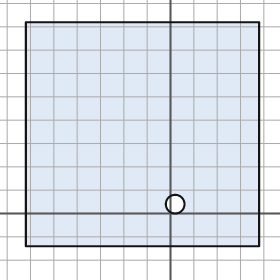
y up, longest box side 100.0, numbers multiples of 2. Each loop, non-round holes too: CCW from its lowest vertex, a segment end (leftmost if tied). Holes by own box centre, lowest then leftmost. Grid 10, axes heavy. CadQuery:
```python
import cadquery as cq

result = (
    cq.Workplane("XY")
    .moveTo(-62.0, -14.0)
    .lineTo(38.0, -14.0)
    .lineTo(38.0, 82.0)
    .lineTo(-62.0, 82.0)
    .close()
    .moveTo(2.0, 4.0)
    .circle(4.0)
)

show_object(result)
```